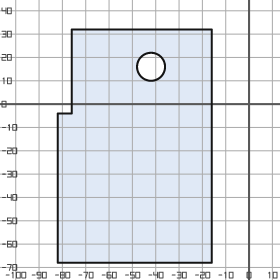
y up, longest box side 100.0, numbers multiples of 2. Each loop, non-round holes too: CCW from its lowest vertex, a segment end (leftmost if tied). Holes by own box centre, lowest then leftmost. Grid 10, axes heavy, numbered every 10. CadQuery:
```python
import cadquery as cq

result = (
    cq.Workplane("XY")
    .moveTo(-82.0, -68.0)
    .lineTo(-16.0, -68.0)
    .lineTo(-16.0, 32.0)
    .lineTo(-76.0, 32.0)
    .lineTo(-76.0, -4.0)
    .lineTo(-82.0, -4.0)
    .close()
    .moveTo(-42.0, 16.0)
    .circle(6.0)
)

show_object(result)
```